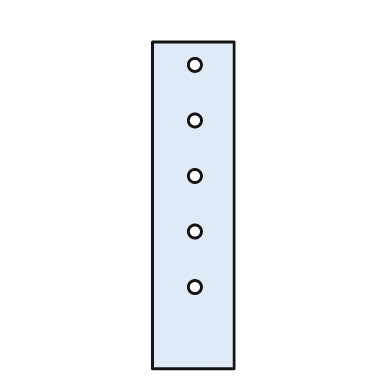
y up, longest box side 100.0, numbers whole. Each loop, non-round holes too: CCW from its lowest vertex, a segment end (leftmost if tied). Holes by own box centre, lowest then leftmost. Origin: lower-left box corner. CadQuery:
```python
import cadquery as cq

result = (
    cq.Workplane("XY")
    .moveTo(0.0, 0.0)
    .lineTo(25.0, 0.0)
    .lineTo(25.0, 100.0)
    .lineTo(0.0, 100.0)
    .close()
    .moveTo(13.0, 25.0)
    .circle(2.0)
    .moveTo(13.0, 42.0)
    .circle(2.0)
    .moveTo(13.0, 59.0)
    .circle(2.0)
    .moveTo(13.0, 76.0)
    .circle(2.0)
    .moveTo(13.0, 93.0)
    .circle(2.0)
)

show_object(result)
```